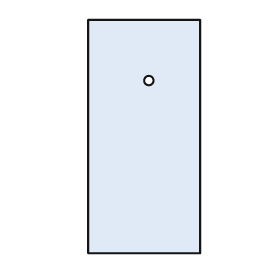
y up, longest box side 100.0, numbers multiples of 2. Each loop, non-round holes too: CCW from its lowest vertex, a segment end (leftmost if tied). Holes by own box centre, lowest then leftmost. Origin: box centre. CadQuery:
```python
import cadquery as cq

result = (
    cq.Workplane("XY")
    .moveTo(-24.0, -50.0)
    .lineTo(24.0, -50.0)
    .lineTo(24.0, 50.0)
    .lineTo(-24.0, 50.0)
    .close()
    .moveTo(2.0, 24.0)
    .circle(2.0)
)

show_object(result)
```